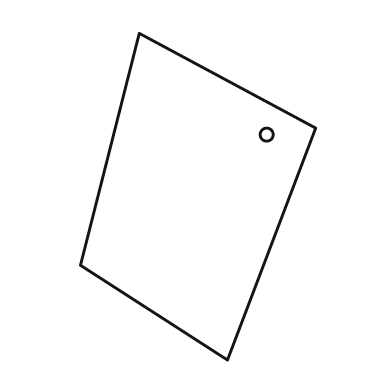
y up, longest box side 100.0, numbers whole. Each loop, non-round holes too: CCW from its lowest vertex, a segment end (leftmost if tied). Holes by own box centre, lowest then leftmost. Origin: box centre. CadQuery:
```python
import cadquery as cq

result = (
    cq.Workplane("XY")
    .moveTo(9.0, -50.0)
    .lineTo(36.0, 21.0)
    .lineTo(-18.0, 50.0)
    .lineTo(-36.0, -21.0)
    .close()
    .moveTo(21.0, 19.0)
    .circle(2.0)
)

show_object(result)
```